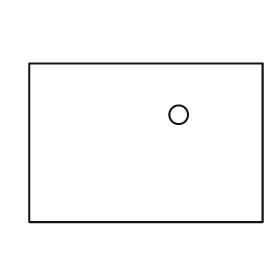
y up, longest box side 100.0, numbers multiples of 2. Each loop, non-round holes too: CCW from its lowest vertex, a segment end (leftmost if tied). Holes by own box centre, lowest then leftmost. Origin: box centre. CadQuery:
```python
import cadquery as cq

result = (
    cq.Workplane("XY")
    .moveTo(-50.0, -34.0)
    .lineTo(50.0, -34.0)
    .lineTo(50.0, 34.0)
    .lineTo(-50.0, 34.0)
    .close()
    .moveTo(14.0, 12.0)
    .circle(4.0)
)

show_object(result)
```